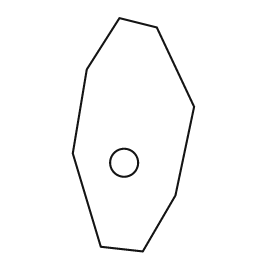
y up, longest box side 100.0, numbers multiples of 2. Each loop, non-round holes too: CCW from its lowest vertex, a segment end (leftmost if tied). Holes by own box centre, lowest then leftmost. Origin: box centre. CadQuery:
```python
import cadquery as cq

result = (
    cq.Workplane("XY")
    .moveTo(4.0, -50.0)
    .lineTo(18.0, -26.0)
    .lineTo(26.0, 12.0)
    .lineTo(10.0, 46.0)
    .lineTo(-6.0, 50.0)
    .lineTo(-20.0, 28.0)
    .lineTo(-26.0, -8.0)
    .lineTo(-14.0, -48.0)
    .close()
    .moveTo(-4.0, -12.0)
    .circle(6.0)
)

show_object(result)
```